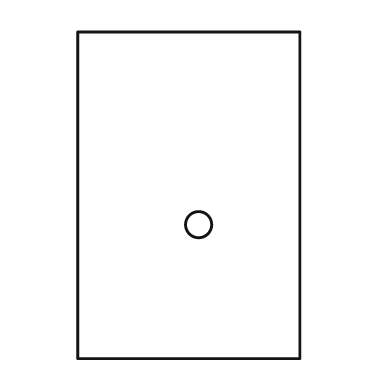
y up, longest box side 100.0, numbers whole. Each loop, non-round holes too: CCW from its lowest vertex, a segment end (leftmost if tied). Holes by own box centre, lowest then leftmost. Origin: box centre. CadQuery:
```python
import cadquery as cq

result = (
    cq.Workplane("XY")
    .moveTo(-34.0, -50.0)
    .lineTo(34.0, -50.0)
    .lineTo(34.0, 50.0)
    .lineTo(-34.0, 50.0)
    .close()
    .moveTo(3.0, -9.0)
    .circle(4.0)
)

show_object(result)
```